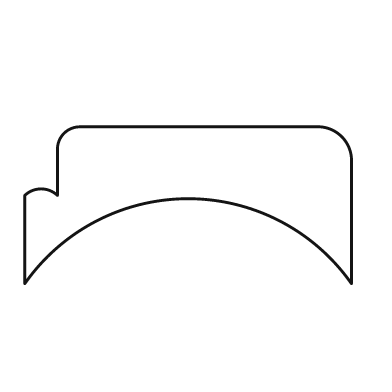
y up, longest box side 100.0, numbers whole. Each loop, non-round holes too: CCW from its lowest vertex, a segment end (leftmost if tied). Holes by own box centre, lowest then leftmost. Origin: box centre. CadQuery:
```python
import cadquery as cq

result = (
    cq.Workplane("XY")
    .moveTo(-50.0, -24.0)
    .threePointArc((0.0, 2.0), (50.0, -24.0))
    .lineTo(50.0, 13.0)
    .threePointArc((47.0, 21.0), (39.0, 24.0))
    .lineTo(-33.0, 24.0)
    .threePointArc((-38.0, 22.0), (-40.0, 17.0))
    .lineTo(-40.0, 3.0)
    .threePointArc((-45.0, 5.0), (-50.0, 3.0))
    .close()
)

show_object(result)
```